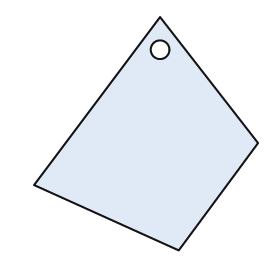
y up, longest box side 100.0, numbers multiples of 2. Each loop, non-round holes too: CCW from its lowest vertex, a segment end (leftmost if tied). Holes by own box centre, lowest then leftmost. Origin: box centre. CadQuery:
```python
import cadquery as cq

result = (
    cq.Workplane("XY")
    .moveTo(14.0, -50.0)
    .lineTo(48.0, -4.0)
    .lineTo(6.0, 50.0)
    .lineTo(-48.0, -22.0)
    .close()
    .moveTo(6.0, 36.0)
    .circle(4.0)
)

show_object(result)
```